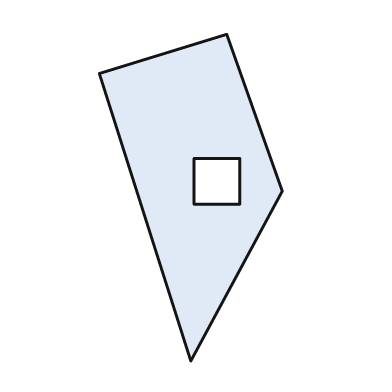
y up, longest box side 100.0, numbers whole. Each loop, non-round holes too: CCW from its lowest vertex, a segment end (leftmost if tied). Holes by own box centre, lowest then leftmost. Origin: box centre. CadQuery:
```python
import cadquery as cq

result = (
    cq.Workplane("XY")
    .moveTo(0.0, -50.0)
    .lineTo(28.0, 2.0)
    .lineTo(11.0, 50.0)
    .lineTo(-28.0, 38.0)
    .close()
    .moveTo(1.0, -2.0)
    .lineTo(15.0, -2.0)
    .lineTo(15.0, 12.0)
    .lineTo(1.0, 12.0)
    .close()
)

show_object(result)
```